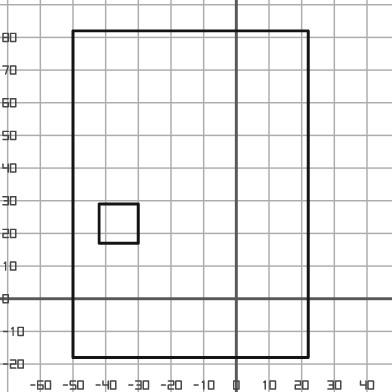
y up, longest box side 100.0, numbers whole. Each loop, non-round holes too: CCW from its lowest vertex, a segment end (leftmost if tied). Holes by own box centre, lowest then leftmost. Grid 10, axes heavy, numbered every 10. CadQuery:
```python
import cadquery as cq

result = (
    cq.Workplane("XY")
    .moveTo(-50.0, -18.0)
    .lineTo(22.0, -18.0)
    .lineTo(22.0, 82.0)
    .lineTo(-50.0, 82.0)
    .close()
    .moveTo(-42.0, 17.0)
    .lineTo(-30.0, 17.0)
    .lineTo(-30.0, 29.0)
    .lineTo(-42.0, 29.0)
    .close()
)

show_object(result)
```